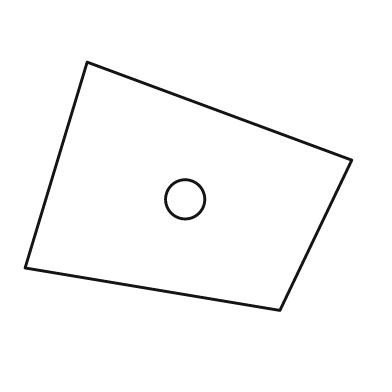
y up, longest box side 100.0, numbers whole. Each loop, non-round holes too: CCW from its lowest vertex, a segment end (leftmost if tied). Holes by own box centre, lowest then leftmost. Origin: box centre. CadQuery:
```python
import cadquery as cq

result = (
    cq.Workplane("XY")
    .moveTo(28.0, -38.0)
    .lineTo(50.0, 8.0)
    .lineTo(-31.0, 38.0)
    .lineTo(-50.0, -25.0)
    .close()
    .moveTo(-1.0, -4.0)
    .circle(6.0)
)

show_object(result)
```